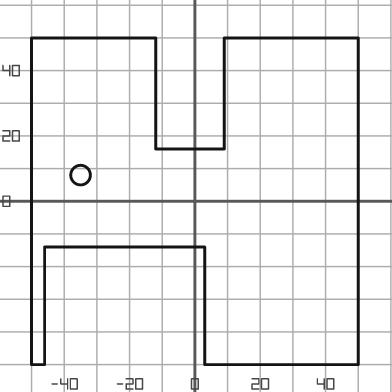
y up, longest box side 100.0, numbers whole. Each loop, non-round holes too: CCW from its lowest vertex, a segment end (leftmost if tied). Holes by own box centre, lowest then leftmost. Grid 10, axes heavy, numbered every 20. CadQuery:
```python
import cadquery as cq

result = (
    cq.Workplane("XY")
    .moveTo(-50.0, -50.0)
    .lineTo(-46.0, -50.0)
    .lineTo(-46.0, -14.0)
    .lineTo(3.0, -14.0)
    .lineTo(3.0, -50.0)
    .lineTo(50.0, -50.0)
    .lineTo(50.0, 50.0)
    .lineTo(9.0, 50.0)
    .lineTo(9.0, 16.0)
    .lineTo(-12.0, 16.0)
    .lineTo(-12.0, 50.0)
    .lineTo(-50.0, 50.0)
    .close()
    .moveTo(-35.0, 8.0)
    .circle(3.0)
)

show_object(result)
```